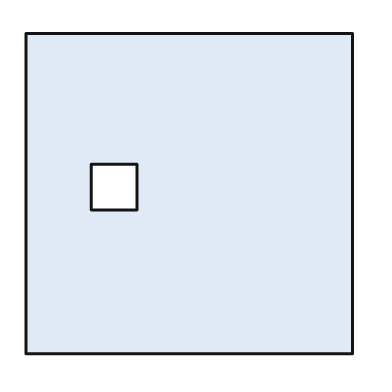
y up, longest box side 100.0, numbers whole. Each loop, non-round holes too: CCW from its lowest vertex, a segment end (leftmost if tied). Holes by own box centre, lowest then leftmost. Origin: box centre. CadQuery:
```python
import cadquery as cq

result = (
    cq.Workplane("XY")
    .moveTo(-50.0, -49.0)
    .lineTo(50.0, -49.0)
    .lineTo(50.0, 49.0)
    .lineTo(-50.0, 49.0)
    .close()
    .moveTo(-30.0, -5.0)
    .lineTo(-16.0, -5.0)
    .lineTo(-16.0, 9.0)
    .lineTo(-30.0, 9.0)
    .close()
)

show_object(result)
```